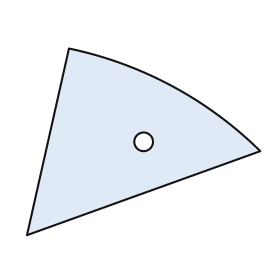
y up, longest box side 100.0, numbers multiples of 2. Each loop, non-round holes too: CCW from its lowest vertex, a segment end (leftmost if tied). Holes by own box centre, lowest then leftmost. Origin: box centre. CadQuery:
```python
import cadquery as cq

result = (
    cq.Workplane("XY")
    .moveTo(-50.0, -40.0)
    .lineTo(50.0, -4.0)
    .threePointArc((12.0, 24.0), (-32.0, 40.0))
    .close()
    .moveTo(0.0, 0.0)
    .circle(4.0)
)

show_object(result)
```